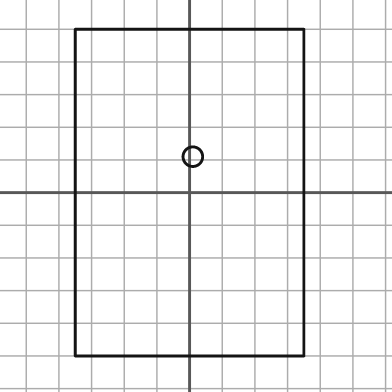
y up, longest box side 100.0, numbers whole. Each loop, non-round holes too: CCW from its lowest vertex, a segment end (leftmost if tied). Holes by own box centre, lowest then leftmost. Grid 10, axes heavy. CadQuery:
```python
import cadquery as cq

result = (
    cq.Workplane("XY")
    .moveTo(-35.0, -50.0)
    .lineTo(35.0, -50.0)
    .lineTo(35.0, 50.0)
    .lineTo(-35.0, 50.0)
    .close()
    .moveTo(1.0, 11.0)
    .circle(3.0)
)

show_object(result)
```